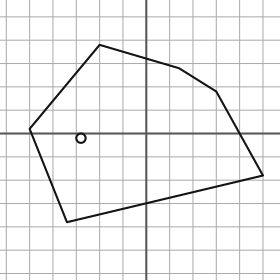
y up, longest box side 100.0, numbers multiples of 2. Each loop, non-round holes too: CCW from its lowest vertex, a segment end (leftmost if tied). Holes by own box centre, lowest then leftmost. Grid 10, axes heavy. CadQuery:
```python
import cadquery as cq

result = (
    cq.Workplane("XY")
    .moveTo(-34.0, -38.0)
    .lineTo(50.0, -18.0)
    .lineTo(30.0, 18.0)
    .lineTo(14.0, 28.0)
    .lineTo(-20.0, 38.0)
    .lineTo(-50.0, 2.0)
    .close()
    .moveTo(-28.0, -2.0)
    .circle(2.0)
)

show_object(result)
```